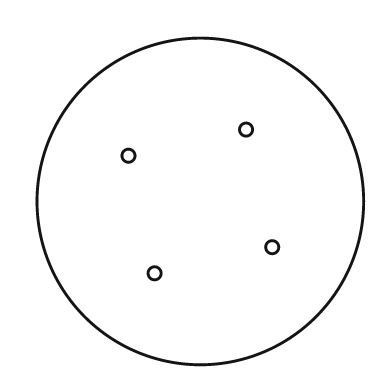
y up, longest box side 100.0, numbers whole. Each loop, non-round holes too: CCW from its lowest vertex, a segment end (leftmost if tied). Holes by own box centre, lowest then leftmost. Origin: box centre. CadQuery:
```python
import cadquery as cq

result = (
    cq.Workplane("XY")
    .moveTo(0.0, 0.0)
    .circle(50.0)
    .moveTo(-14.0, -22.0)
    .circle(2.0)
    .moveTo(22.0, -14.0)
    .circle(2.0)
    .moveTo(-22.0, 14.0)
    .circle(2.0)
    .moveTo(14.0, 22.0)
    .circle(2.0)
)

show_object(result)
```